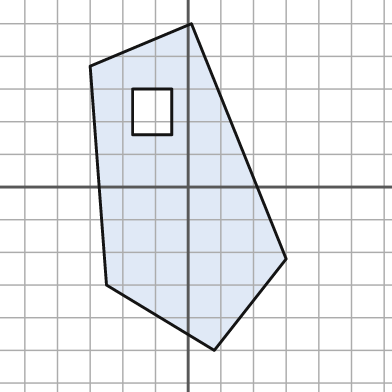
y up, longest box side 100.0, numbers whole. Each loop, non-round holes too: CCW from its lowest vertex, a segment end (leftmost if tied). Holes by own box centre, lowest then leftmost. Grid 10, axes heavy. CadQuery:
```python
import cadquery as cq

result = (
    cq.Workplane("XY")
    .moveTo(8.0, -50.0)
    .lineTo(30.0, -22.0)
    .lineTo(1.0, 50.0)
    .lineTo(-30.0, 37.0)
    .lineTo(-25.0, -30.0)
    .close()
    .moveTo(-17.0, 16.0)
    .lineTo(-5.0, 16.0)
    .lineTo(-5.0, 30.0)
    .lineTo(-17.0, 30.0)
    .close()
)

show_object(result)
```